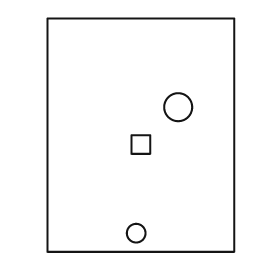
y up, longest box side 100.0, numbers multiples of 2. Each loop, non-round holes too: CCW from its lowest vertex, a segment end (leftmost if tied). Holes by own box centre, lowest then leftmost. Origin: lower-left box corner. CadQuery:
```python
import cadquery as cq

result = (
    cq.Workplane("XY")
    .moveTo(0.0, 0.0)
    .lineTo(80.0, 0.0)
    .lineTo(80.0, 100.0)
    .lineTo(0.0, 100.0)
    .close()
    .moveTo(38.0, 8.0)
    .circle(4.0)
    .moveTo(36.0, 42.0)
    .lineTo(44.0, 42.0)
    .lineTo(44.0, 50.0)
    .lineTo(36.0, 50.0)
    .close()
    .moveTo(56.0, 62.0)
    .circle(6.0)
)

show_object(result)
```